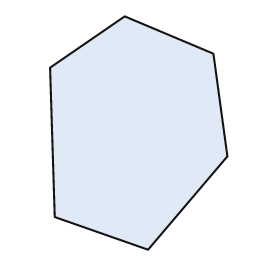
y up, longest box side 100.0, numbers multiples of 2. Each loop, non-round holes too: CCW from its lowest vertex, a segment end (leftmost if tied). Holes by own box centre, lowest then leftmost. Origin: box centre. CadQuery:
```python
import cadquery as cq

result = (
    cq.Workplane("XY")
    .moveTo(4.0, -50.0)
    .lineTo(38.0, -10.0)
    .lineTo(32.0, 34.0)
    .lineTo(-6.0, 50.0)
    .lineTo(-38.0, 28.0)
    .lineTo(-36.0, -36.0)
    .close()
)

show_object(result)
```